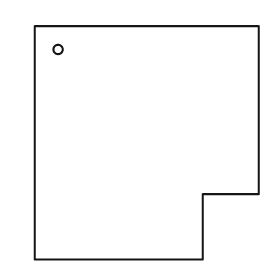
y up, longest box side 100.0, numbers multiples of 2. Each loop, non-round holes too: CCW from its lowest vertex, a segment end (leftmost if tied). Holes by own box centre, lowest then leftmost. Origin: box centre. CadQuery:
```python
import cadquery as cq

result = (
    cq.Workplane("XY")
    .moveTo(-48.0, -50.0)
    .lineTo(24.0, -50.0)
    .lineTo(24.0, -22.0)
    .lineTo(48.0, -22.0)
    .lineTo(48.0, 50.0)
    .lineTo(-48.0, 50.0)
    .close()
    .moveTo(-38.0, 40.0)
    .circle(2.0)
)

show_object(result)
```